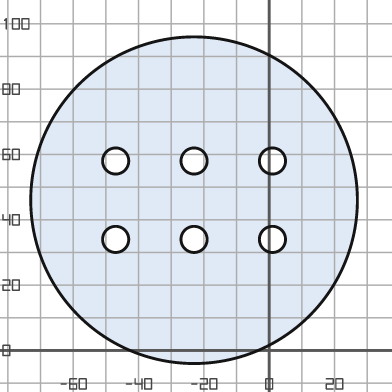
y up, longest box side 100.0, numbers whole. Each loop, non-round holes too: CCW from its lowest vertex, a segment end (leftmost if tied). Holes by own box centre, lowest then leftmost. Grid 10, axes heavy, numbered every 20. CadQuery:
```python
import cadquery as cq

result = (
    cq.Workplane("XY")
    .moveTo(-23.0, 46.0)
    .circle(50.0)
    .moveTo(-47.0, 34.0)
    .circle(4.0)
    .moveTo(-23.0, 34.0)
    .circle(4.0)
    .moveTo(1.0, 34.0)
    .circle(4.0)
    .moveTo(-47.0, 58.0)
    .circle(4.0)
    .moveTo(-23.0, 58.0)
    .circle(4.0)
    .moveTo(1.0, 58.0)
    .circle(4.0)
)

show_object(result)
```